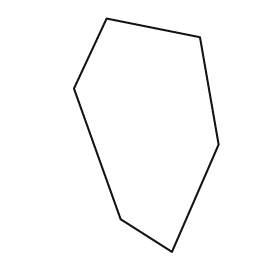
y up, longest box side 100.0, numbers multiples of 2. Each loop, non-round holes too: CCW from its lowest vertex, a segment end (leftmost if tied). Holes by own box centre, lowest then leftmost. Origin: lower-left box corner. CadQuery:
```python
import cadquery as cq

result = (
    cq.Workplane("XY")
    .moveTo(42.0, 0.0)
    .lineTo(62.0, 46.0)
    .lineTo(54.0, 92.0)
    .lineTo(14.0, 100.0)
    .lineTo(0.0, 70.0)
    .lineTo(20.0, 14.0)
    .close()
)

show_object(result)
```